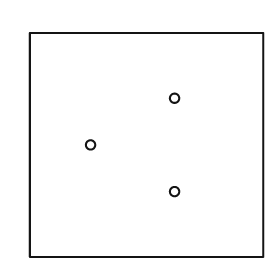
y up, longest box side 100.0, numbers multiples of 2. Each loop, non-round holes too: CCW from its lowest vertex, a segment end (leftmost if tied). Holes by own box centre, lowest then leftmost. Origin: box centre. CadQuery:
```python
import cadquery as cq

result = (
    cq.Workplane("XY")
    .moveTo(-50.0, -48.0)
    .lineTo(50.0, -48.0)
    .lineTo(50.0, 48.0)
    .lineTo(-50.0, 48.0)
    .close()
    .moveTo(12.0, -20.0)
    .circle(2.0)
    .moveTo(-24.0, 0.0)
    .circle(2.0)
    .moveTo(12.0, 20.0)
    .circle(2.0)
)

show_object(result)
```